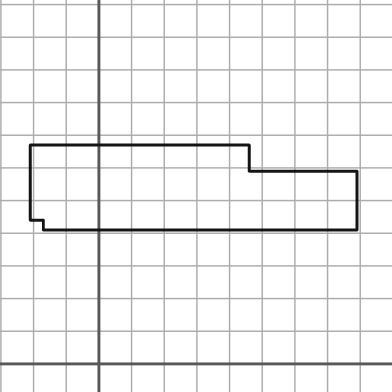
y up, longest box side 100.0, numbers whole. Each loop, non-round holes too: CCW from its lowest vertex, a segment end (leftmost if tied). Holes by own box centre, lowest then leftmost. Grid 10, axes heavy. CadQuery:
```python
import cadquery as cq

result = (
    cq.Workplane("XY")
    .moveTo(-17.0, 41.0)
    .lineTo(79.0, 41.0)
    .lineTo(79.0, 59.0)
    .lineTo(46.0, 59.0)
    .lineTo(46.0, 67.0)
    .lineTo(-21.0, 67.0)
    .lineTo(-21.0, 44.0)
    .lineTo(-17.0, 44.0)
    .close()
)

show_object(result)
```